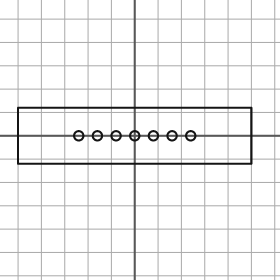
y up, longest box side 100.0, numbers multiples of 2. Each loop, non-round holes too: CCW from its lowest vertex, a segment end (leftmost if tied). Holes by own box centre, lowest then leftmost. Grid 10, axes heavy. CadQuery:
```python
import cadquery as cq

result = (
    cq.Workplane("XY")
    .moveTo(-50.0, -12.0)
    .lineTo(50.0, -12.0)
    .lineTo(50.0, 12.0)
    .lineTo(-50.0, 12.0)
    .close()
    .moveTo(-24.0, 0.0)
    .circle(2.0)
    .moveTo(-16.0, 0.0)
    .circle(2.0)
    .moveTo(-8.0, 0.0)
    .circle(2.0)
    .moveTo(0.0, 0.0)
    .circle(2.0)
    .moveTo(8.0, 0.0)
    .circle(2.0)
    .moveTo(16.0, 0.0)
    .circle(2.0)
    .moveTo(24.0, 0.0)
    .circle(2.0)
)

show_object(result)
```